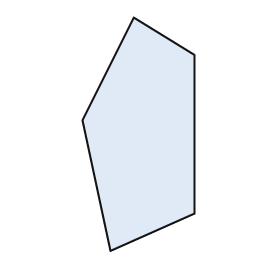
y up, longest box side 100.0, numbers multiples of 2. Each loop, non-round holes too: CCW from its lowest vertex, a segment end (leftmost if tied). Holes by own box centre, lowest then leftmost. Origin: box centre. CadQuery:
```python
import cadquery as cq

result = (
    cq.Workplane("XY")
    .moveTo(-12.0, -50.0)
    .lineTo(24.0, -34.0)
    .lineTo(24.0, 34.0)
    .lineTo(-2.0, 50.0)
    .lineTo(-24.0, 6.0)
    .close()
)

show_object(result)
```